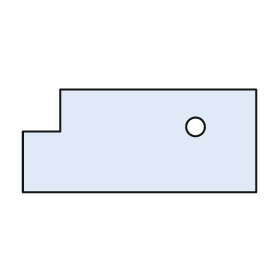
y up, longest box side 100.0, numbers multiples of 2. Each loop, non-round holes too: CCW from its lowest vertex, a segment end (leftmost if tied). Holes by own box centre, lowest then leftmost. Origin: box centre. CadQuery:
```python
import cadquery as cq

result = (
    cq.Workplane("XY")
    .moveTo(-50.0, -22.0)
    .lineTo(50.0, -22.0)
    .lineTo(50.0, 22.0)
    .lineTo(-34.0, 22.0)
    .lineTo(-34.0, 4.0)
    .lineTo(-50.0, 4.0)
    .close()
    .moveTo(24.0, 6.0)
    .circle(4.0)
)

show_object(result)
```